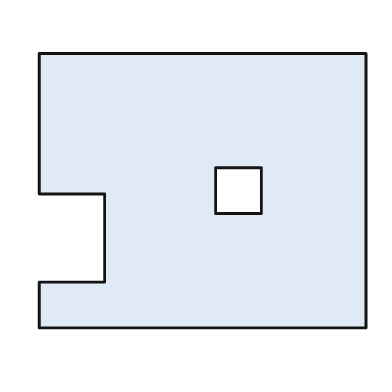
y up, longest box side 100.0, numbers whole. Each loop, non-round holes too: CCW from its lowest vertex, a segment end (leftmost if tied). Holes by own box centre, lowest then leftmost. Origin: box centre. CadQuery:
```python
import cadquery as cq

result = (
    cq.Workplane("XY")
    .moveTo(-50.0, -42.0)
    .lineTo(50.0, -42.0)
    .lineTo(50.0, 42.0)
    .lineTo(-50.0, 42.0)
    .lineTo(-50.0, -1.0)
    .lineTo(-30.0, -1.0)
    .lineTo(-30.0, -28.0)
    .lineTo(-50.0, -28.0)
    .close()
    .moveTo(4.0, -7.0)
    .lineTo(18.0, -7.0)
    .lineTo(18.0, 7.0)
    .lineTo(4.0, 7.0)
    .close()
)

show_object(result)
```